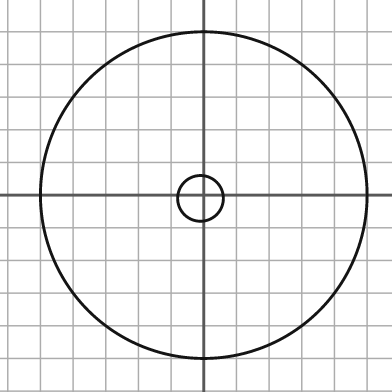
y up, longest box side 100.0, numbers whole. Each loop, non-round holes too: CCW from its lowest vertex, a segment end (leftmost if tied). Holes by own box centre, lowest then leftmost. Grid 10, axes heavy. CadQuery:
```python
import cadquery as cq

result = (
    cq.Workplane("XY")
    .moveTo(0.0, 0.0)
    .circle(50.0)
    .moveTo(-1.0, -1.0)
    .circle(7.0)
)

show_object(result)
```